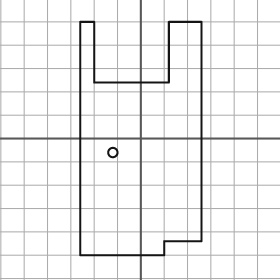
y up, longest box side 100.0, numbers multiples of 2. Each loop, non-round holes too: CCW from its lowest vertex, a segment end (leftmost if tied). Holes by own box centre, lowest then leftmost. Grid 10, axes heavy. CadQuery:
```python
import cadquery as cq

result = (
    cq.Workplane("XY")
    .moveTo(-26.0, -50.0)
    .lineTo(10.0, -50.0)
    .lineTo(10.0, -44.0)
    .lineTo(26.0, -44.0)
    .lineTo(26.0, 50.0)
    .lineTo(12.0, 50.0)
    .lineTo(12.0, 24.0)
    .lineTo(-20.0, 24.0)
    .lineTo(-20.0, 50.0)
    .lineTo(-26.0, 50.0)
    .close()
    .moveTo(-12.0, -6.0)
    .circle(2.0)
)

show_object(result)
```